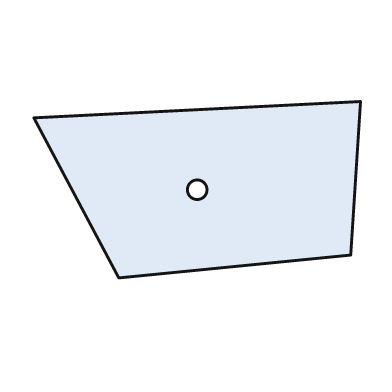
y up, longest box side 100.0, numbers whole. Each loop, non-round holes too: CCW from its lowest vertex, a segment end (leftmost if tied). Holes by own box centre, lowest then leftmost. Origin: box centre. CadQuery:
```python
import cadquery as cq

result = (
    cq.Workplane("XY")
    .moveTo(-24.0, -27.0)
    .lineTo(47.0, -20.0)
    .lineTo(50.0, 27.0)
    .lineTo(-50.0, 22.0)
    .close()
    .moveTo(0.0, 0.0)
    .circle(3.0)
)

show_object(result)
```